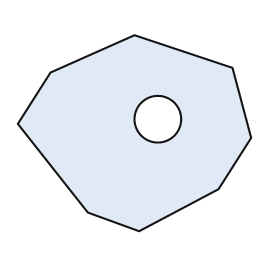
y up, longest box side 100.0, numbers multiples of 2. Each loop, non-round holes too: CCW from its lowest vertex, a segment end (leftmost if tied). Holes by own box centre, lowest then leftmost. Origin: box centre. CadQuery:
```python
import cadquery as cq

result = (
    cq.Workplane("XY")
    .moveTo(2.0, -42.0)
    .lineTo(36.0, -24.0)
    .lineTo(50.0, -2.0)
    .lineTo(42.0, 28.0)
    .lineTo(0.0, 42.0)
    .lineTo(-36.0, 26.0)
    .lineTo(-50.0, 4.0)
    .lineTo(-20.0, -34.0)
    .close()
    .moveTo(10.0, 6.0)
    .circle(10.0)
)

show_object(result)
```